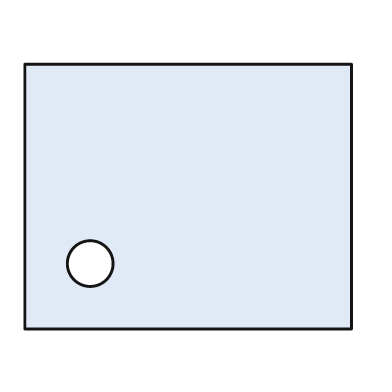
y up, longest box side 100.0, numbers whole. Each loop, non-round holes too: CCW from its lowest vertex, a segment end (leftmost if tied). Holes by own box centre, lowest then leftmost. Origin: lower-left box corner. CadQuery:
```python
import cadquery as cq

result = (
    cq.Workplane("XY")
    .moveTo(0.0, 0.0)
    .lineTo(100.0, 0.0)
    .lineTo(100.0, 81.0)
    .lineTo(0.0, 81.0)
    .close()
    .moveTo(20.0, 20.0)
    .circle(7.0)
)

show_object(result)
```